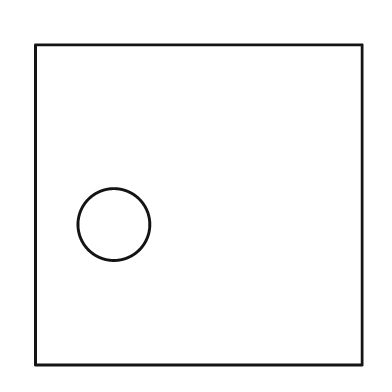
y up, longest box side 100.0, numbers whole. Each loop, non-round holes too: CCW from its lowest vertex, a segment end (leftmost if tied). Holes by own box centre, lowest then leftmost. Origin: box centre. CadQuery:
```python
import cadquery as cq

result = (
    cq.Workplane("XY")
    .moveTo(-50.0, -49.0)
    .lineTo(50.0, -49.0)
    .lineTo(50.0, 49.0)
    .lineTo(-50.0, 49.0)
    .close()
    .moveTo(-26.0, -6.0)
    .circle(11.0)
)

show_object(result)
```